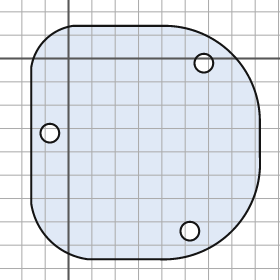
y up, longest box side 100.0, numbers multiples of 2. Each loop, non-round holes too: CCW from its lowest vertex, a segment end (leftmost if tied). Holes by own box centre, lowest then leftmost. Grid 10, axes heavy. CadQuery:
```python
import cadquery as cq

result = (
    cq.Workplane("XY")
    .moveTo(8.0, -86.0)
    .lineTo(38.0, -86.0)
    .threePointArc((70.0, -74.0), (82.0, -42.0))
    .lineTo(82.0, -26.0)
    .threePointArc((70.0, 2.0), (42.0, 14.0))
    .lineTo(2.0, 14.0)
    .threePointArc((-10.0, 8.0), (-16.0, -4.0))
    .lineTo(-16.0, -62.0)
    .threePointArc((-8.0, -78.0), (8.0, -86.0))
    .close()
    .moveTo(52.0, -74.0)
    .circle(4.0)
    .moveTo(-8.0, -32.0)
    .circle(4.0)
    .moveTo(58.0, -2.0)
    .circle(4.0)
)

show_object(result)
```